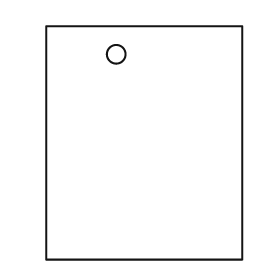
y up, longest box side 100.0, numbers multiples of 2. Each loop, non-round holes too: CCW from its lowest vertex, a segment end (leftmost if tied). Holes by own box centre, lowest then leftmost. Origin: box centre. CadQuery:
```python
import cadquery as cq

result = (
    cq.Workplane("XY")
    .moveTo(-42.0, -50.0)
    .lineTo(42.0, -50.0)
    .lineTo(42.0, 50.0)
    .lineTo(-42.0, 50.0)
    .close()
    .moveTo(-12.0, 38.0)
    .circle(4.0)
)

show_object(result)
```